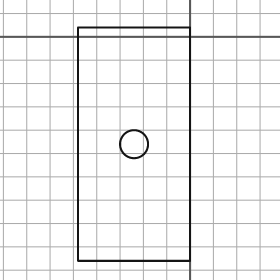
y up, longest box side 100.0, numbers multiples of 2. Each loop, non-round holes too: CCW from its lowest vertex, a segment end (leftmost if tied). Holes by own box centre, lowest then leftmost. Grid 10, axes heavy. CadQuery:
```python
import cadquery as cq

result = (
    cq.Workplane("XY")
    .moveTo(-48.0, -96.0)
    .lineTo(0.0, -96.0)
    .lineTo(0.0, 4.0)
    .lineTo(-48.0, 4.0)
    .close()
    .moveTo(-24.0, -46.0)
    .circle(6.0)
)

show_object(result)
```